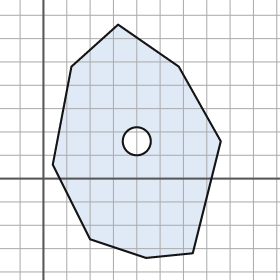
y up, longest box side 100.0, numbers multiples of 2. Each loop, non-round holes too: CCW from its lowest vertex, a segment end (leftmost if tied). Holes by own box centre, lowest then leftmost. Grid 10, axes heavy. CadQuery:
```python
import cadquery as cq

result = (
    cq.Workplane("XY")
    .moveTo(44.0, -34.0)
    .lineTo(64.0, -32.0)
    .lineTo(76.0, 16.0)
    .lineTo(58.0, 48.0)
    .lineTo(32.0, 66.0)
    .lineTo(12.0, 48.0)
    .lineTo(4.0, 6.0)
    .lineTo(20.0, -26.0)
    .close()
    .moveTo(40.0, 16.0)
    .circle(6.0)
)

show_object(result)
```